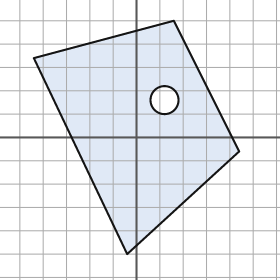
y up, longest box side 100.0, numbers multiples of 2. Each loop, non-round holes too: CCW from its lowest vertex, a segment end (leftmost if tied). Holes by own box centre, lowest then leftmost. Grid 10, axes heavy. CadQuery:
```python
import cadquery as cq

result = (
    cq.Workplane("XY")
    .moveTo(-4.0, -50.0)
    .lineTo(44.0, -6.0)
    .lineTo(16.0, 50.0)
    .lineTo(-44.0, 34.0)
    .close()
    .moveTo(12.0, 16.0)
    .circle(6.0)
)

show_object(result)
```